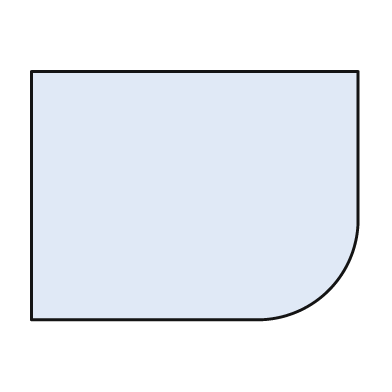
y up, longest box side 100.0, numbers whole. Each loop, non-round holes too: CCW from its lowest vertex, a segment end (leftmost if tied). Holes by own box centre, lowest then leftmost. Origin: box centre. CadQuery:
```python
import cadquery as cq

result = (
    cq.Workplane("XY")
    .moveTo(-50.0, -38.0)
    .lineTo(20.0, -38.0)
    .threePointArc((41.0, -29.0), (50.0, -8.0))
    .lineTo(50.0, 38.0)
    .lineTo(-50.0, 38.0)
    .close()
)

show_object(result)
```